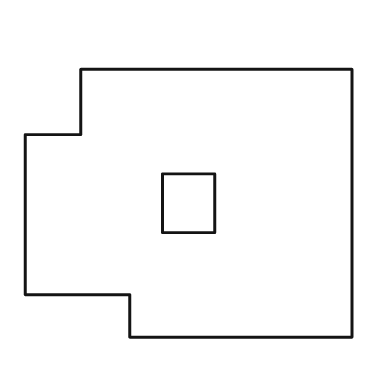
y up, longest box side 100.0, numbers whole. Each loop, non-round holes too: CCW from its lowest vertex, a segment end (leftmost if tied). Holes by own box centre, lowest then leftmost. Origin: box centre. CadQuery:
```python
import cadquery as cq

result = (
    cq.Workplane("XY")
    .moveTo(-18.0, -41.0)
    .lineTo(50.0, -41.0)
    .lineTo(50.0, 41.0)
    .lineTo(-33.0, 41.0)
    .lineTo(-33.0, 21.0)
    .lineTo(-50.0, 21.0)
    .lineTo(-50.0, -28.0)
    .lineTo(-18.0, -28.0)
    .close()
    .moveTo(-8.0, -9.0)
    .lineTo(8.0, -9.0)
    .lineTo(8.0, 9.0)
    .lineTo(-8.0, 9.0)
    .close()
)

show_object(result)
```